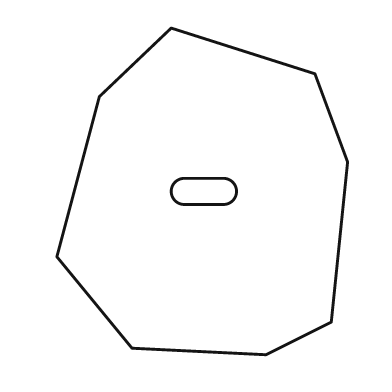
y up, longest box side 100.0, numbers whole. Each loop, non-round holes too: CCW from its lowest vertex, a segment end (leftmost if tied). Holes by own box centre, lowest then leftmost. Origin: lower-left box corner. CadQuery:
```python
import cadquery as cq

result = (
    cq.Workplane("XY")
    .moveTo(64.0, 0.0)
    .lineTo(84.0, 10.0)
    .lineTo(89.0, 59.0)
    .lineTo(79.0, 86.0)
    .lineTo(35.0, 100.0)
    .lineTo(13.0, 79.0)
    .lineTo(0.0, 30.0)
    .lineTo(23.0, 2.0)
    .close()
    .moveTo(39.0, 46.0)
    .lineTo(51.0, 46.0)
    .threePointArc((55.0, 50.0), (51.0, 54.0))
    .lineTo(39.0, 54.0)
    .threePointArc((35.0, 50.0), (39.0, 46.0))
    .close()
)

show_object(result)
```